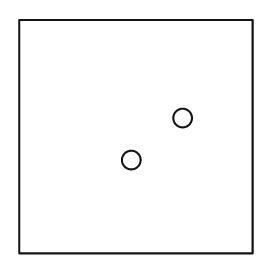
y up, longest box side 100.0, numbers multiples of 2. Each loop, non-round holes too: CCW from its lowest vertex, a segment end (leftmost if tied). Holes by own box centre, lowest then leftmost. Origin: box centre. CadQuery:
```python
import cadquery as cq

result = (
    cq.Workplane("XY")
    .moveTo(-50.0, -50.0)
    .lineTo(50.0, -50.0)
    .lineTo(50.0, 50.0)
    .lineTo(-50.0, 50.0)
    .close()
    .moveTo(-2.0, -10.0)
    .circle(4.0)
    .moveTo(20.0, 8.0)
    .circle(4.0)
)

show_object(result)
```